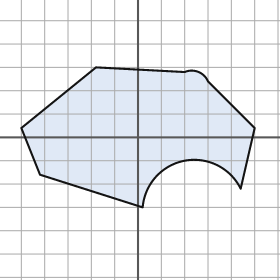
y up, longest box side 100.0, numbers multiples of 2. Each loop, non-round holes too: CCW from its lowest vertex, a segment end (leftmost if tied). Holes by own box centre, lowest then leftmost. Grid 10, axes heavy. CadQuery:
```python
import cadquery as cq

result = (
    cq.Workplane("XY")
    .moveTo(2.0, -30.0)
    .threePointArc((20.0, -10.0), (44.0, -22.0))
    .lineTo(50.0, 4.0)
    .lineTo(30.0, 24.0)
    .threePointArc((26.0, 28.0), (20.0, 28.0))
    .lineTo(-18.0, 30.0)
    .lineTo(-50.0, 4.0)
    .lineTo(-42.0, -16.0)
    .close()
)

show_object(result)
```